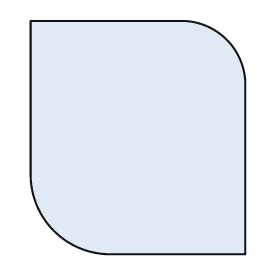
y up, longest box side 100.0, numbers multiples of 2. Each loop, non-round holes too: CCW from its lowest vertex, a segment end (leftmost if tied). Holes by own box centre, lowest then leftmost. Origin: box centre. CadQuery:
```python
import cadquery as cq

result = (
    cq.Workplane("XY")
    .moveTo(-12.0, -50.0)
    .lineTo(46.0, -50.0)
    .lineTo(46.0, 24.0)
    .threePointArc((38.0, 42.0), (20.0, 50.0))
    .lineTo(-46.0, 50.0)
    .lineTo(-46.0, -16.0)
    .threePointArc((-36.0, -40.0), (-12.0, -50.0))
    .close()
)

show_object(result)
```